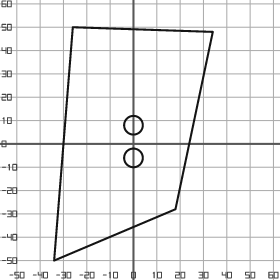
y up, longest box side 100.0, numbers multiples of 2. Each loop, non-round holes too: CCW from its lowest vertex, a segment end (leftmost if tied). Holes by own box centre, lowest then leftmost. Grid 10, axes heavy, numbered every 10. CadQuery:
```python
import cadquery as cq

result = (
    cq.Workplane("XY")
    .moveTo(-34.0, -50.0)
    .lineTo(18.0, -28.0)
    .lineTo(34.0, 48.0)
    .lineTo(-26.0, 50.0)
    .close()
    .moveTo(0.0, -6.0)
    .circle(4.0)
    .moveTo(0.0, 8.0)
    .circle(4.0)
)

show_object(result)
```